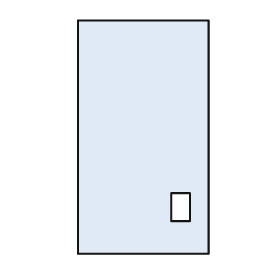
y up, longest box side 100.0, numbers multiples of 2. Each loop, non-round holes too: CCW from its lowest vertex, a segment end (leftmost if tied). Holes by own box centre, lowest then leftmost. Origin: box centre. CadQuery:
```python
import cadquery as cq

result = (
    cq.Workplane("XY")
    .moveTo(-28.0, -50.0)
    .lineTo(28.0, -50.0)
    .lineTo(28.0, 50.0)
    .lineTo(-28.0, 50.0)
    .close()
    .moveTo(12.0, -36.0)
    .lineTo(20.0, -36.0)
    .lineTo(20.0, -24.0)
    .lineTo(12.0, -24.0)
    .close()
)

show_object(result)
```